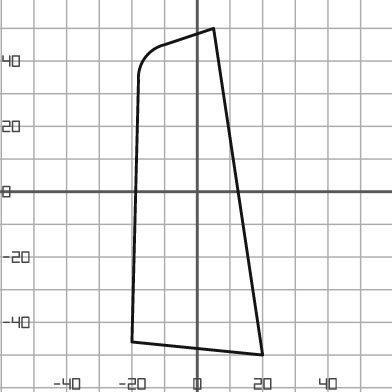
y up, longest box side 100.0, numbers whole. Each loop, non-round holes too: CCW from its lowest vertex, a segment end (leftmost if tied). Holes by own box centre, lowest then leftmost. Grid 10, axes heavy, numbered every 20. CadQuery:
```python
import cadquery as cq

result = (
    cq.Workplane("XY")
    .moveTo(20.0, -50.0)
    .lineTo(5.0, 50.0)
    .lineTo(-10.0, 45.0)
    .threePointArc((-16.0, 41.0), (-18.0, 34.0))
    .lineTo(-20.0, -46.0)
    .close()
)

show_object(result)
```